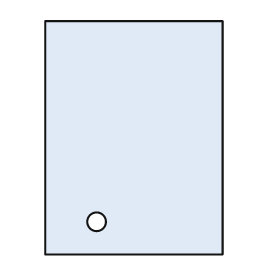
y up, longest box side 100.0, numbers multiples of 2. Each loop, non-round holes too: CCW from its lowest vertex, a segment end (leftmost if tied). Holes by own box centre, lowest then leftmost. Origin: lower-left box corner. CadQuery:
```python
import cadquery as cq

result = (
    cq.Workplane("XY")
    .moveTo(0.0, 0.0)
    .lineTo(76.0, 0.0)
    .lineTo(76.0, 100.0)
    .lineTo(0.0, 100.0)
    .close()
    .moveTo(22.0, 14.0)
    .circle(4.0)
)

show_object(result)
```